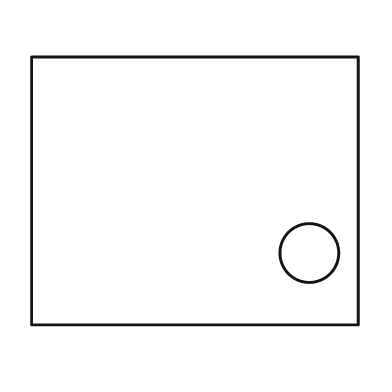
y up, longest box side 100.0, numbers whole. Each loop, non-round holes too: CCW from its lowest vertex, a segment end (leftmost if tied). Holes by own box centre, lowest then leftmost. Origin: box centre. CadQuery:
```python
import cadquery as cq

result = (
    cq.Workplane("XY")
    .moveTo(-50.0, -41.0)
    .lineTo(50.0, -41.0)
    .lineTo(50.0, 41.0)
    .lineTo(-50.0, 41.0)
    .close()
    .moveTo(35.0, -19.0)
    .circle(9.0)
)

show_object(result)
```